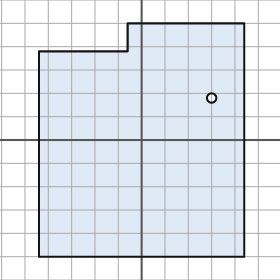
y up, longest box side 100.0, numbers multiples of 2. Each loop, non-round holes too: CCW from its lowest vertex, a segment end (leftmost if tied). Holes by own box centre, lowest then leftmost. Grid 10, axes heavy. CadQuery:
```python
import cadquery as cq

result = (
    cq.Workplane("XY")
    .moveTo(-44.0, -50.0)
    .lineTo(44.0, -50.0)
    .lineTo(44.0, 50.0)
    .lineTo(-6.0, 50.0)
    .lineTo(-6.0, 38.0)
    .lineTo(-44.0, 38.0)
    .close()
    .moveTo(30.0, 18.0)
    .circle(2.0)
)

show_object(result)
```